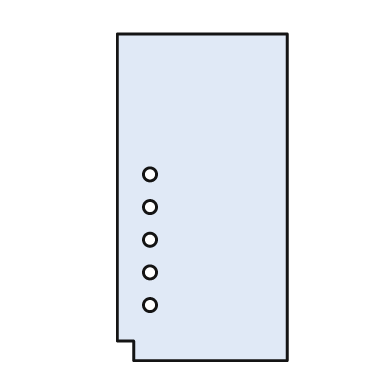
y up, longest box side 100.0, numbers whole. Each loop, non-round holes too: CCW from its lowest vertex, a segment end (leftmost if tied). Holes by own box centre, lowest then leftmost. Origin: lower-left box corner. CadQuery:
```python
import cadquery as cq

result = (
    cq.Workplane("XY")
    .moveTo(5.0, 0.0)
    .lineTo(52.0, 0.0)
    .lineTo(52.0, 100.0)
    .lineTo(0.0, 100.0)
    .lineTo(0.0, 6.0)
    .lineTo(5.0, 6.0)
    .close()
    .moveTo(10.0, 17.0)
    .circle(2.0)
    .moveTo(10.0, 27.0)
    .circle(2.0)
    .moveTo(10.0, 37.0)
    .circle(2.0)
    .moveTo(10.0, 47.0)
    .circle(2.0)
    .moveTo(10.0, 57.0)
    .circle(2.0)
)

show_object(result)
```